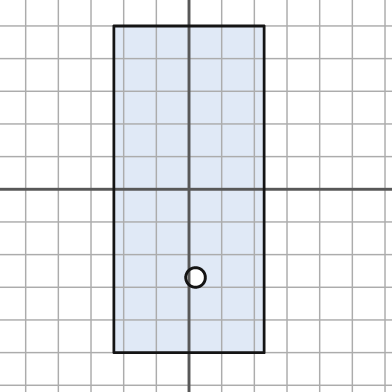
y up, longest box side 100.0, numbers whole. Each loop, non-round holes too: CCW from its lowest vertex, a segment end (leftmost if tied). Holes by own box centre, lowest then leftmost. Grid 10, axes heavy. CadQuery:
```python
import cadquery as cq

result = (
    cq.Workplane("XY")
    .moveTo(-23.0, -50.0)
    .lineTo(23.0, -50.0)
    .lineTo(23.0, 50.0)
    .lineTo(-23.0, 50.0)
    .close()
    .moveTo(2.0, -27.0)
    .circle(3.0)
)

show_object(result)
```